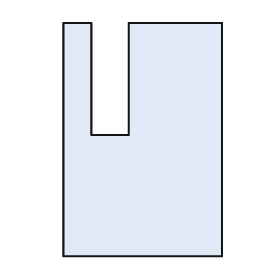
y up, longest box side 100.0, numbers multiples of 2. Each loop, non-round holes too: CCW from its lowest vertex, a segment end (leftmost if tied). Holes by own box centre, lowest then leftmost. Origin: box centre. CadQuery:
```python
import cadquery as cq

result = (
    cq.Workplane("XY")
    .moveTo(-34.0, -50.0)
    .lineTo(34.0, -50.0)
    .lineTo(34.0, 50.0)
    .lineTo(-6.0, 50.0)
    .lineTo(-6.0, 2.0)
    .lineTo(-22.0, 2.0)
    .lineTo(-22.0, 50.0)
    .lineTo(-34.0, 50.0)
    .close()
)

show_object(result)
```